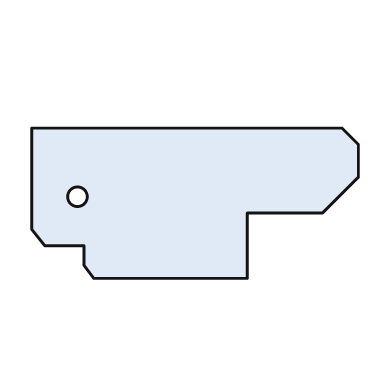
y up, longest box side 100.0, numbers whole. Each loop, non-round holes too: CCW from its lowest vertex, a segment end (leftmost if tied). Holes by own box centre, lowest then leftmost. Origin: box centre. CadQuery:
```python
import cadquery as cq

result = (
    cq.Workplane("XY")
    .moveTo(-31.0, -23.0)
    .lineTo(16.0, -23.0)
    .lineTo(16.0, -3.0)
    .lineTo(39.0, -3.0)
    .lineTo(50.0, 8.0)
    .lineTo(50.0, 18.0)
    .lineTo(45.0, 23.0)
    .lineTo(-50.0, 23.0)
    .lineTo(-50.0, -8.0)
    .lineTo(-46.0, -13.0)
    .lineTo(-34.0, -13.0)
    .lineTo(-34.0, -19.0)
    .close()
    .moveTo(-36.0, 2.0)
    .circle(3.0)
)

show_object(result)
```